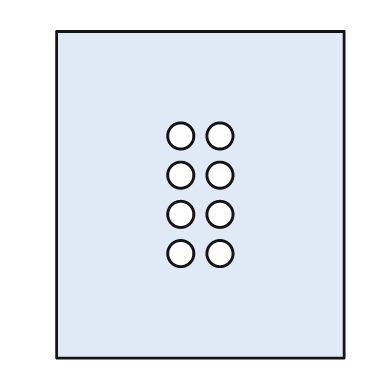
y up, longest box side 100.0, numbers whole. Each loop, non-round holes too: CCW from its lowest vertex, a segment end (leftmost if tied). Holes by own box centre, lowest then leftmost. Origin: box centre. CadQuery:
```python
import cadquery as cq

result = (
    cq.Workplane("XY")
    .moveTo(-44.0, -50.0)
    .lineTo(44.0, -50.0)
    .lineTo(44.0, 50.0)
    .lineTo(-44.0, 50.0)
    .close()
    .moveTo(-6.0, -18.0)
    .circle(4.0)
    .moveTo(6.0, -18.0)
    .circle(4.0)
    .moveTo(-6.0, -6.0)
    .circle(4.0)
    .moveTo(6.0, -6.0)
    .circle(4.0)
    .moveTo(-6.0, 6.0)
    .circle(4.0)
    .moveTo(6.0, 6.0)
    .circle(4.0)
    .moveTo(-6.0, 18.0)
    .circle(4.0)
    .moveTo(6.0, 18.0)
    .circle(4.0)
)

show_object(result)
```